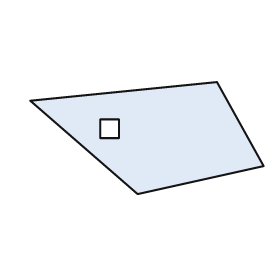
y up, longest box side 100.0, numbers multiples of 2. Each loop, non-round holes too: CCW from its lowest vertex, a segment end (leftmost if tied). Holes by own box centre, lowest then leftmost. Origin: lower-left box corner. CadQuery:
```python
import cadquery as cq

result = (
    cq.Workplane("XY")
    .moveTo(46.0, 0.0)
    .lineTo(100.0, 12.0)
    .lineTo(80.0, 48.0)
    .lineTo(0.0, 40.0)
    .close()
    .moveTo(30.0, 24.0)
    .lineTo(38.0, 24.0)
    .lineTo(38.0, 32.0)
    .lineTo(30.0, 32.0)
    .close()
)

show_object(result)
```